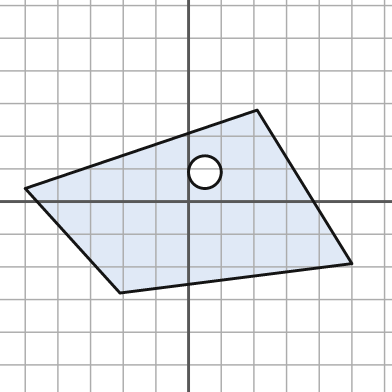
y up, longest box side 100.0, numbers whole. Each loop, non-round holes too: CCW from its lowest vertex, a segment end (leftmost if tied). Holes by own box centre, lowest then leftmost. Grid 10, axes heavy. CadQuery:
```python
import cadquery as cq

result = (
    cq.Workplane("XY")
    .moveTo(-21.0, -28.0)
    .lineTo(50.0, -19.0)
    .lineTo(21.0, 28.0)
    .lineTo(-50.0, 4.0)
    .close()
    .moveTo(5.0, 9.0)
    .circle(5.0)
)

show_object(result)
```